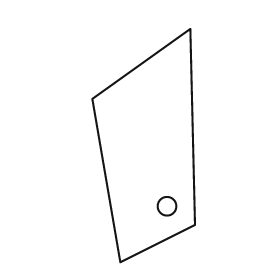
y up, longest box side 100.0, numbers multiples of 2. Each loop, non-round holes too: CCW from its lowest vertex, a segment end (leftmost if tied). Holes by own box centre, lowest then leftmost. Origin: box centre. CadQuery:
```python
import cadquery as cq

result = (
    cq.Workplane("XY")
    .moveTo(-10.0, -50.0)
    .lineTo(22.0, -34.0)
    .lineTo(20.0, 50.0)
    .lineTo(-22.0, 20.0)
    .close()
    .moveTo(10.0, -26.0)
    .circle(4.0)
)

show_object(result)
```